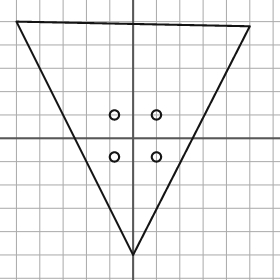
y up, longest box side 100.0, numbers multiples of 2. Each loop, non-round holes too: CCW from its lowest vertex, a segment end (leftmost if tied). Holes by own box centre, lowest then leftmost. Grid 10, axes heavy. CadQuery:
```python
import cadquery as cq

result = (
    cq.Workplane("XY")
    .moveTo(0.0, -50.0)
    .lineTo(50.0, 48.0)
    .lineTo(-50.0, 50.0)
    .close()
    .moveTo(-8.0, -8.0)
    .circle(2.0)
    .moveTo(10.0, -8.0)
    .circle(2.0)
    .moveTo(-8.0, 10.0)
    .circle(2.0)
    .moveTo(10.0, 10.0)
    .circle(2.0)
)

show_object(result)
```